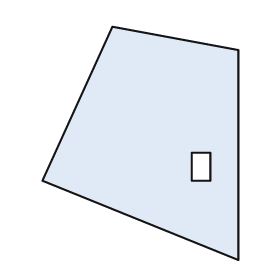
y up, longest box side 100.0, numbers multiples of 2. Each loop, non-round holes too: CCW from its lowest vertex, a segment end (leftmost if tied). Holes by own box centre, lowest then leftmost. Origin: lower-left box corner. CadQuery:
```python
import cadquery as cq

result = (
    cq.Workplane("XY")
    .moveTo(84.0, 0.0)
    .lineTo(84.0, 90.0)
    .lineTo(30.0, 100.0)
    .lineTo(0.0, 34.0)
    .close()
    .moveTo(64.0, 34.0)
    .lineTo(72.0, 34.0)
    .lineTo(72.0, 46.0)
    .lineTo(64.0, 46.0)
    .close()
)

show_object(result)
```